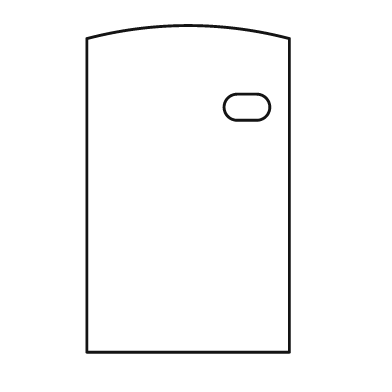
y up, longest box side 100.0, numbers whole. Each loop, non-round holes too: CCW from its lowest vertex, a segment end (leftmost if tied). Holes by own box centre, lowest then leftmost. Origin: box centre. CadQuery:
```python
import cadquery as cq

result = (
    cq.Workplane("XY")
    .moveTo(-31.0, -50.0)
    .lineTo(31.0, -50.0)
    .lineTo(31.0, 46.0)
    .threePointArc((0.0, 50.0), (-31.0, 46.0))
    .close()
    .moveTo(15.0, 21.0)
    .lineTo(21.0, 21.0)
    .threePointArc((25.0, 25.0), (21.0, 29.0))
    .lineTo(15.0, 29.0)
    .threePointArc((11.0, 25.0), (15.0, 21.0))
    .close()
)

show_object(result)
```